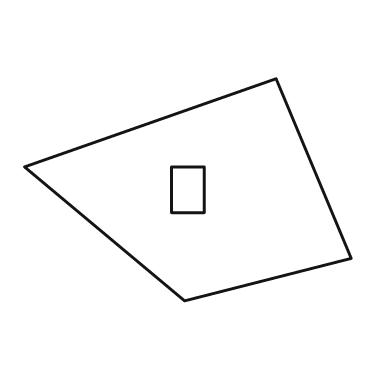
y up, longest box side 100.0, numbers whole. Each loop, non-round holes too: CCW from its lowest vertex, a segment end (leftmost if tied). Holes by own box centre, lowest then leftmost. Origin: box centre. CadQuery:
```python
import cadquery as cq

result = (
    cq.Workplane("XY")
    .moveTo(-1.0, -34.0)
    .lineTo(50.0, -21.0)
    .lineTo(27.0, 34.0)
    .lineTo(-50.0, 7.0)
    .close()
    .moveTo(-5.0, -7.0)
    .lineTo(5.0, -7.0)
    .lineTo(5.0, 7.0)
    .lineTo(-5.0, 7.0)
    .close()
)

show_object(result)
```